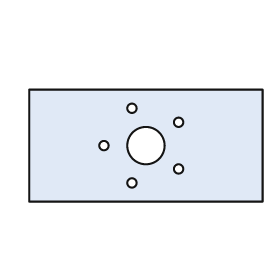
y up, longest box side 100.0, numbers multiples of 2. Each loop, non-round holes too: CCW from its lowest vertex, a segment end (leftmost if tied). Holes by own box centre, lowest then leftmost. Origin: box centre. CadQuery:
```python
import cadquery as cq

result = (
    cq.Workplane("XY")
    .moveTo(-50.0, -24.0)
    .lineTo(50.0, -24.0)
    .lineTo(50.0, 24.0)
    .lineTo(-50.0, 24.0)
    .close()
    .moveTo(-6.0, -16.0)
    .circle(2.0)
    .moveTo(14.0, -10.0)
    .circle(2.0)
    .moveTo(-18.0, 0.0)
    .circle(2.0)
    .moveTo(0.0, 0.0)
    .circle(8.0)
    .moveTo(14.0, 10.0)
    .circle(2.0)
    .moveTo(-6.0, 16.0)
    .circle(2.0)
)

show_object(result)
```